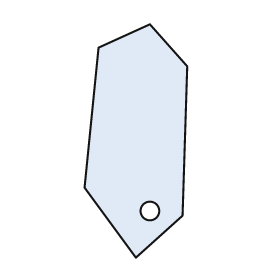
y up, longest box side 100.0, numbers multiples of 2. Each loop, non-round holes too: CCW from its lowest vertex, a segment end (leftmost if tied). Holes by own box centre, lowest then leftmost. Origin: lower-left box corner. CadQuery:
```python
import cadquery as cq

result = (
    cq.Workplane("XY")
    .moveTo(22.0, 0.0)
    .lineTo(42.0, 18.0)
    .lineTo(44.0, 82.0)
    .lineTo(28.0, 100.0)
    .lineTo(6.0, 90.0)
    .lineTo(0.0, 30.0)
    .close()
    .moveTo(28.0, 20.0)
    .circle(4.0)
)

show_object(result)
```